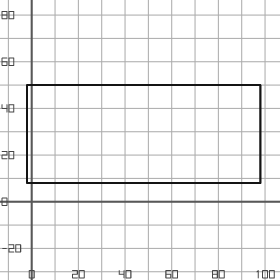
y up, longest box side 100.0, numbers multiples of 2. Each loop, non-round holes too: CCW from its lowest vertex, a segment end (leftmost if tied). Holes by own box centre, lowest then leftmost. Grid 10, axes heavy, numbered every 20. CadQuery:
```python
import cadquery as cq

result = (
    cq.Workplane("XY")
    .moveTo(-2.0, 8.0)
    .lineTo(98.0, 8.0)
    .lineTo(98.0, 50.0)
    .lineTo(-2.0, 50.0)
    .close()
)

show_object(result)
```